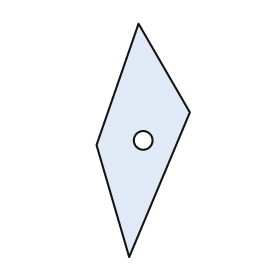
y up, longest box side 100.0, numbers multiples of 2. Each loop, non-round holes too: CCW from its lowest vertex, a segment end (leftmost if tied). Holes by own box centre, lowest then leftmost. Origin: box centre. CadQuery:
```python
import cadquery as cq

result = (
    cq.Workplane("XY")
    .moveTo(-6.0, -50.0)
    .lineTo(20.0, 12.0)
    .lineTo(-2.0, 50.0)
    .lineTo(-20.0, -2.0)
    .close()
    .moveTo(0.0, 0.0)
    .circle(4.0)
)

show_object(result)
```